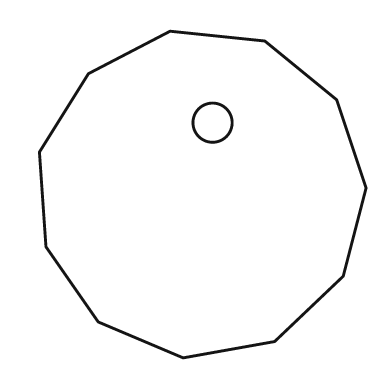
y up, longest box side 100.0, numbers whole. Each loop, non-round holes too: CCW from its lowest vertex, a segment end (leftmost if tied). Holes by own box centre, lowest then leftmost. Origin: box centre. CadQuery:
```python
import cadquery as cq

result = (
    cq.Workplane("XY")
    .moveTo(-6.0, -50.0)
    .lineTo(22.0, -45.0)
    .lineTo(43.0, -25.0)
    .lineTo(50.0, 2.0)
    .lineTo(41.0, 29.0)
    .lineTo(19.0, 47.0)
    .lineTo(-10.0, 50.0)
    .lineTo(-35.0, 37.0)
    .lineTo(-50.0, 13.0)
    .lineTo(-48.0, -16.0)
    .lineTo(-32.0, -39.0)
    .close()
    .moveTo(3.0, 22.0)
    .circle(6.0)
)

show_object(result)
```